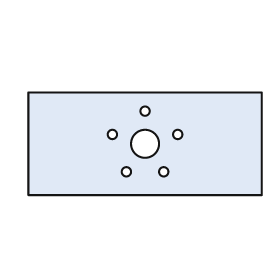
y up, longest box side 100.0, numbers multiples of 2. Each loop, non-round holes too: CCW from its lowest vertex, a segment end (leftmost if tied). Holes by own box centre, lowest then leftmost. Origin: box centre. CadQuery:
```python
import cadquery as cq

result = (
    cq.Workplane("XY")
    .moveTo(-50.0, -22.0)
    .lineTo(50.0, -22.0)
    .lineTo(50.0, 22.0)
    .lineTo(-50.0, 22.0)
    .close()
    .moveTo(-8.0, -12.0)
    .circle(2.0)
    .moveTo(8.0, -12.0)
    .circle(2.0)
    .moveTo(0.0, 0.0)
    .circle(6.0)
    .moveTo(-14.0, 4.0)
    .circle(2.0)
    .moveTo(14.0, 4.0)
    .circle(2.0)
    .moveTo(0.0, 14.0)
    .circle(2.0)
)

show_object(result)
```